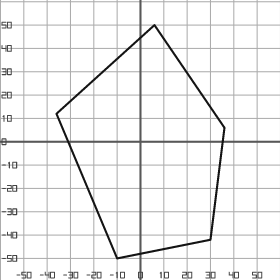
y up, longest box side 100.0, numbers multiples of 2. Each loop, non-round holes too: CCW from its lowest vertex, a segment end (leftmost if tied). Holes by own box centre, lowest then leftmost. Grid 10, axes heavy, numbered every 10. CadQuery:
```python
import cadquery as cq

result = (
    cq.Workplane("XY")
    .moveTo(-10.0, -50.0)
    .lineTo(30.0, -42.0)
    .lineTo(36.0, 6.0)
    .lineTo(6.0, 50.0)
    .lineTo(-36.0, 12.0)
    .close()
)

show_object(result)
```